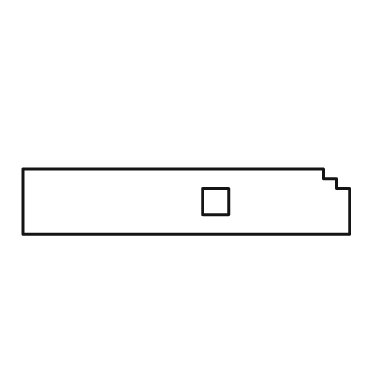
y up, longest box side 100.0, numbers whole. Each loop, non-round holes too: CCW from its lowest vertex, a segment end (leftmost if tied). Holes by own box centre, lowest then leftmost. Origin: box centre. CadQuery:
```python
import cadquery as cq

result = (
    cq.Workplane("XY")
    .moveTo(-50.0, -10.0)
    .lineTo(50.0, -10.0)
    .lineTo(50.0, 4.0)
    .lineTo(46.0, 4.0)
    .lineTo(46.0, 7.0)
    .lineTo(42.0, 7.0)
    .lineTo(42.0, 10.0)
    .lineTo(-50.0, 10.0)
    .close()
    .moveTo(5.0, -4.0)
    .lineTo(13.0, -4.0)
    .lineTo(13.0, 4.0)
    .lineTo(5.0, 4.0)
    .close()
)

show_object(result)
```